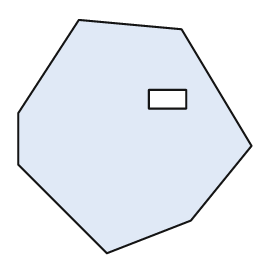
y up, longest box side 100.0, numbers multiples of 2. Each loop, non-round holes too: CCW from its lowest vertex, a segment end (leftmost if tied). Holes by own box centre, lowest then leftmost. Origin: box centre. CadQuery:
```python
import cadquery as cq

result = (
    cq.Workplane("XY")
    .moveTo(-12.0, -50.0)
    .lineTo(24.0, -36.0)
    .lineTo(50.0, -4.0)
    .lineTo(20.0, 46.0)
    .lineTo(-24.0, 50.0)
    .lineTo(-50.0, 10.0)
    .lineTo(-50.0, -12.0)
    .close()
    .moveTo(6.0, 12.0)
    .lineTo(22.0, 12.0)
    .lineTo(22.0, 20.0)
    .lineTo(6.0, 20.0)
    .close()
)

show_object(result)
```